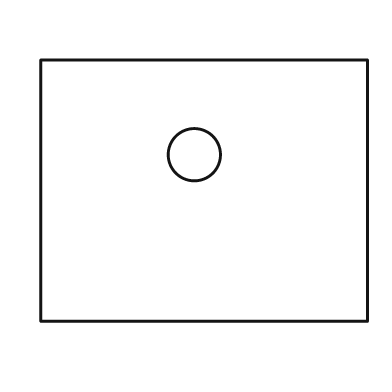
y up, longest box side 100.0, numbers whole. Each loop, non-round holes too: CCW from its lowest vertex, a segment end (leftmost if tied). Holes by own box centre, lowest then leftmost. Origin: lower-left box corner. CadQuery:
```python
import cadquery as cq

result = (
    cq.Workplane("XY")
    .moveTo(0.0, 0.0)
    .lineTo(100.0, 0.0)
    .lineTo(100.0, 80.0)
    .lineTo(0.0, 80.0)
    .close()
    .moveTo(47.0, 51.0)
    .circle(8.0)
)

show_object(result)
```